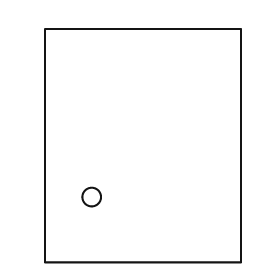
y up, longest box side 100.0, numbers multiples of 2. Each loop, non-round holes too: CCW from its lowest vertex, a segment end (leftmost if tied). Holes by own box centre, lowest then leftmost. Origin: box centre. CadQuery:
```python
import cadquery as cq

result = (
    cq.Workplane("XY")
    .moveTo(-42.0, -50.0)
    .lineTo(42.0, -50.0)
    .lineTo(42.0, 50.0)
    .lineTo(-42.0, 50.0)
    .close()
    .moveTo(-22.0, -22.0)
    .circle(4.0)
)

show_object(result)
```